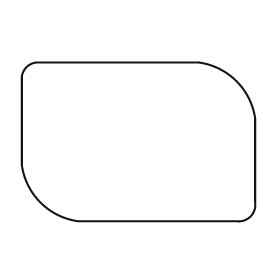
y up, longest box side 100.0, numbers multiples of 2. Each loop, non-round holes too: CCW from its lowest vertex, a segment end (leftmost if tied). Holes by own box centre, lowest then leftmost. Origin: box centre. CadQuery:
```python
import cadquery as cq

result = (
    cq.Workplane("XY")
    .moveTo(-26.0, -34.0)
    .lineTo(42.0, -34.0)
    .threePointArc((48.0, -32.0), (50.0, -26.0))
    .lineTo(50.0, 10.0)
    .threePointArc((42.0, 26.0), (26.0, 34.0))
    .lineTo(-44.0, 34.0)
    .threePointArc((-48.0, 32.0), (-50.0, 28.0))
    .lineTo(-50.0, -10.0)
    .threePointArc((-42.0, -26.0), (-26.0, -34.0))
    .close()
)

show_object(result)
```